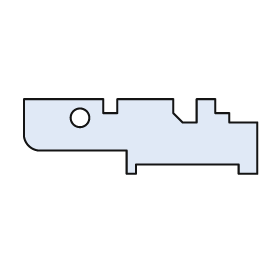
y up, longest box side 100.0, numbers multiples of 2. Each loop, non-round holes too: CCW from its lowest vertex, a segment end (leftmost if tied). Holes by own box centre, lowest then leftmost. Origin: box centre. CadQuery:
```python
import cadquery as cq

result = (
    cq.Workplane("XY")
    .moveTo(-6.0, -16.0)
    .lineTo(-2.0, -16.0)
    .lineTo(-2.0, -12.0)
    .lineTo(42.0, -12.0)
    .lineTo(42.0, -16.0)
    .lineTo(50.0, -16.0)
    .lineTo(50.0, 6.0)
    .lineTo(38.0, 6.0)
    .lineTo(38.0, 10.0)
    .lineTo(32.0, 10.0)
    .lineTo(32.0, 16.0)
    .lineTo(24.0, 16.0)
    .lineTo(24.0, 6.0)
    .lineTo(18.0, 6.0)
    .lineTo(14.0, 10.0)
    .lineTo(14.0, 16.0)
    .lineTo(-10.0, 16.0)
    .lineTo(-10.0, 10.0)
    .lineTo(-16.0, 10.0)
    .lineTo(-16.0, 16.0)
    .lineTo(-50.0, 16.0)
    .lineTo(-50.0, 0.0)
    .threePointArc((-48.0, -4.0), (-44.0, -6.0))
    .lineTo(-6.0, -6.0)
    .close()
    .moveTo(-26.0, 8.0)
    .circle(4.0)
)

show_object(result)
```